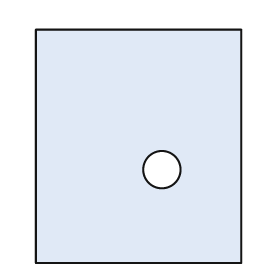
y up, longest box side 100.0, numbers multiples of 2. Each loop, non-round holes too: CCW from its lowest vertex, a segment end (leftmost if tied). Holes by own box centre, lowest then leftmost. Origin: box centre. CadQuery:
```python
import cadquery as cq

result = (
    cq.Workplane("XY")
    .moveTo(-44.0, -50.0)
    .lineTo(44.0, -50.0)
    .lineTo(44.0, 50.0)
    .lineTo(-44.0, 50.0)
    .close()
    .moveTo(10.0, -10.0)
    .circle(8.0)
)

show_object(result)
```